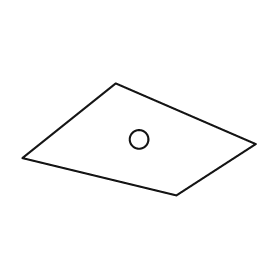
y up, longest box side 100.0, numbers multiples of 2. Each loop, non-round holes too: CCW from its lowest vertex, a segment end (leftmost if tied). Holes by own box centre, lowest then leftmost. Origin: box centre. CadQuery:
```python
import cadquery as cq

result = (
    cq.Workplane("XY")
    .moveTo(16.0, -24.0)
    .lineTo(50.0, -2.0)
    .lineTo(-10.0, 24.0)
    .lineTo(-50.0, -8.0)
    .close()
    .moveTo(0.0, 0.0)
    .circle(4.0)
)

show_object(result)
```